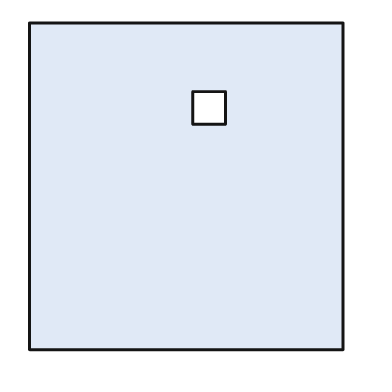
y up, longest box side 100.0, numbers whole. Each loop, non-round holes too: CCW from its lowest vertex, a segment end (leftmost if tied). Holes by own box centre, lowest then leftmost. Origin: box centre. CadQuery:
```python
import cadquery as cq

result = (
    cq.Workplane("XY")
    .moveTo(-48.0, -50.0)
    .lineTo(48.0, -50.0)
    .lineTo(48.0, 50.0)
    .lineTo(-48.0, 50.0)
    .close()
    .moveTo(2.0, 19.0)
    .lineTo(12.0, 19.0)
    .lineTo(12.0, 29.0)
    .lineTo(2.0, 29.0)
    .close()
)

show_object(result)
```